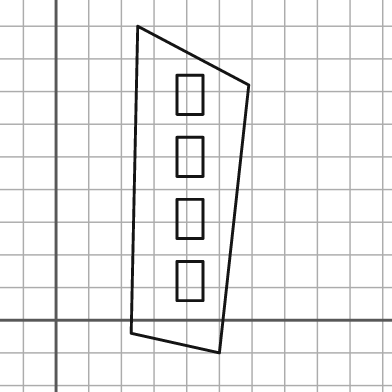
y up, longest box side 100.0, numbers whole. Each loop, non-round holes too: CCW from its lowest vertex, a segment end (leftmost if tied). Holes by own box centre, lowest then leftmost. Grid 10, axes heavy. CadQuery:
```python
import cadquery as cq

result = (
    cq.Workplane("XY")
    .moveTo(50.0, -10.0)
    .lineTo(59.0, 72.0)
    .lineTo(25.0, 90.0)
    .lineTo(23.0, -4.0)
    .close()
    .moveTo(37.0, 6.0)
    .lineTo(45.0, 6.0)
    .lineTo(45.0, 18.0)
    .lineTo(37.0, 18.0)
    .close()
    .moveTo(37.0, 25.0)
    .lineTo(45.0, 25.0)
    .lineTo(45.0, 37.0)
    .lineTo(37.0, 37.0)
    .close()
    .moveTo(37.0, 44.0)
    .lineTo(45.0, 44.0)
    .lineTo(45.0, 56.0)
    .lineTo(37.0, 56.0)
    .close()
    .moveTo(37.0, 63.0)
    .lineTo(45.0, 63.0)
    .lineTo(45.0, 75.0)
    .lineTo(37.0, 75.0)
    .close()
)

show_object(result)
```